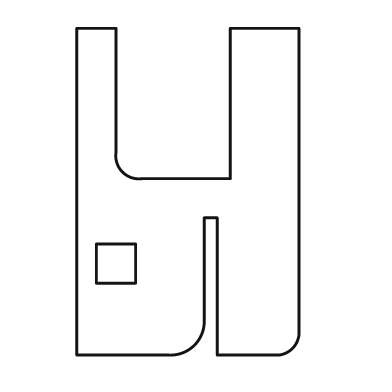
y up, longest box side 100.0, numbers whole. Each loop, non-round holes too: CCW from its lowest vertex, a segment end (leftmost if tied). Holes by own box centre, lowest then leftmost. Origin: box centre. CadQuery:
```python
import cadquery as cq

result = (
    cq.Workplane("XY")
    .moveTo(-34.0, -50.0)
    .lineTo(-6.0, -50.0)
    .threePointArc((2.0, -47.0), (5.0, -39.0))
    .lineTo(5.0, -8.0)
    .lineTo(9.0, -8.0)
    .lineTo(9.0, -50.0)
    .lineTo(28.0, -50.0)
    .threePointArc((32.0, -48.0), (34.0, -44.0))
    .lineTo(34.0, 50.0)
    .lineTo(13.0, 50.0)
    .lineTo(13.0, 4.0)
    .lineTo(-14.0, 4.0)
    .threePointArc((-20.0, 6.0), (-22.0, 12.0))
    .lineTo(-22.0, 50.0)
    .lineTo(-34.0, 50.0)
    .close()
    .moveTo(-28.0, -28.0)
    .lineTo(-16.0, -28.0)
    .lineTo(-16.0, -16.0)
    .lineTo(-28.0, -16.0)
    .close()
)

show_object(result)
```